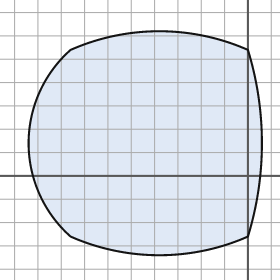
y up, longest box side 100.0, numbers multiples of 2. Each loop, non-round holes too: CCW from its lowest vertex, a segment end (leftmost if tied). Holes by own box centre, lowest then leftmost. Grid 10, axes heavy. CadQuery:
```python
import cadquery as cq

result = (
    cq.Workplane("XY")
    .moveTo(-76.0, -26.0)
    .threePointArc((-38.0, -34.0), (0.0, -26.0))
    .threePointArc((6.0, 14.0), (0.0, 54.0))
    .threePointArc((-38.0, 62.0), (-76.0, 54.0))
    .threePointArc((-94.0, 14.0), (-76.0, -26.0))
    .close()
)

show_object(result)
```